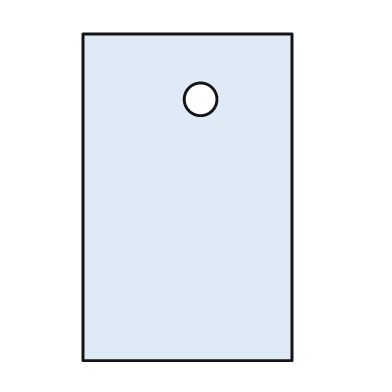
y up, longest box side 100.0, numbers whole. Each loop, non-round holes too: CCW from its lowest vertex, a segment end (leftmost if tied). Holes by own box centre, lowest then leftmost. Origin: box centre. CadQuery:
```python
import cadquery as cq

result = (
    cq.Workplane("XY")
    .moveTo(-32.0, -50.0)
    .lineTo(32.0, -50.0)
    .lineTo(32.0, 50.0)
    .lineTo(-32.0, 50.0)
    .close()
    .moveTo(4.0, 30.0)
    .circle(5.0)
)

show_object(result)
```